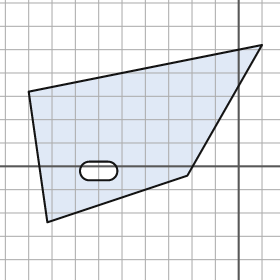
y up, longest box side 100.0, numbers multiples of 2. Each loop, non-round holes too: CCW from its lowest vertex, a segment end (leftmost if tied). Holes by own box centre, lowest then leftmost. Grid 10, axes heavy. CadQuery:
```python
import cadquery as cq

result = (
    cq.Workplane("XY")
    .moveTo(-82.0, -24.0)
    .lineTo(-22.0, -4.0)
    .lineTo(10.0, 52.0)
    .lineTo(-90.0, 32.0)
    .close()
    .moveTo(-64.0, -6.0)
    .lineTo(-56.0, -6.0)
    .threePointArc((-52.0, -2.0), (-56.0, 2.0))
    .lineTo(-64.0, 2.0)
    .threePointArc((-68.0, -2.0), (-64.0, -6.0))
    .close()
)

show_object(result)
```